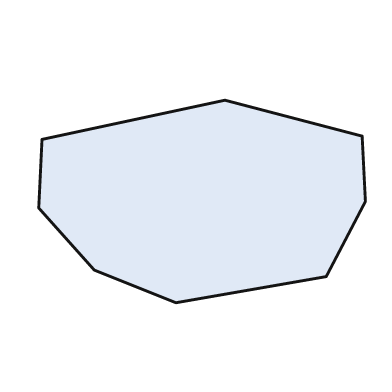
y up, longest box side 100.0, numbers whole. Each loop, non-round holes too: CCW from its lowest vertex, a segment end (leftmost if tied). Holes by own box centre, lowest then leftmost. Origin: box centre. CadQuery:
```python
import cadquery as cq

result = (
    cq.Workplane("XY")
    .moveTo(-8.0, -31.0)
    .lineTo(38.0, -23.0)
    .lineTo(50.0, 0.0)
    .lineTo(49.0, 20.0)
    .lineTo(7.0, 31.0)
    .lineTo(-49.0, 19.0)
    .lineTo(-50.0, -2.0)
    .lineTo(-33.0, -21.0)
    .close()
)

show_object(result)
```